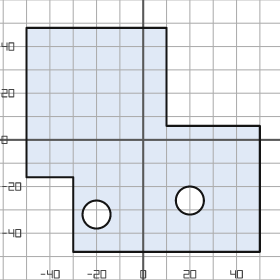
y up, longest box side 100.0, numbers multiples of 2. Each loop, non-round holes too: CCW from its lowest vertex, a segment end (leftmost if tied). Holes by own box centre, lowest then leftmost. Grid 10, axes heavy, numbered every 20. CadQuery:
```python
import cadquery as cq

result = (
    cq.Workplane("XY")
    .moveTo(-30.0, -48.0)
    .lineTo(50.0, -48.0)
    .lineTo(50.0, 6.0)
    .lineTo(10.0, 6.0)
    .lineTo(10.0, 48.0)
    .lineTo(-50.0, 48.0)
    .lineTo(-50.0, -16.0)
    .lineTo(-30.0, -16.0)
    .close()
    .moveTo(-20.0, -32.0)
    .circle(6.0)
    .moveTo(20.0, -26.0)
    .circle(6.0)
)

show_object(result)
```